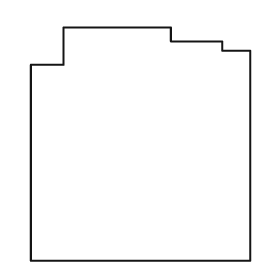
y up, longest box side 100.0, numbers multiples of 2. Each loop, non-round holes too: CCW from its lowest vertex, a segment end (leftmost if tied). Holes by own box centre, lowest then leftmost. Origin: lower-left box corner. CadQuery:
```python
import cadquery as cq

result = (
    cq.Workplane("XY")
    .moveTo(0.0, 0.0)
    .lineTo(94.0, 0.0)
    .lineTo(94.0, 90.0)
    .lineTo(82.0, 90.0)
    .lineTo(82.0, 94.0)
    .lineTo(60.0, 94.0)
    .lineTo(60.0, 100.0)
    .lineTo(14.0, 100.0)
    .lineTo(14.0, 84.0)
    .lineTo(0.0, 84.0)
    .close()
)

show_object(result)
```